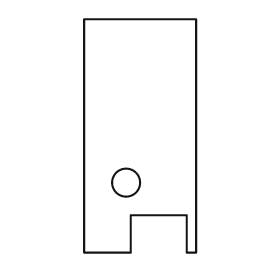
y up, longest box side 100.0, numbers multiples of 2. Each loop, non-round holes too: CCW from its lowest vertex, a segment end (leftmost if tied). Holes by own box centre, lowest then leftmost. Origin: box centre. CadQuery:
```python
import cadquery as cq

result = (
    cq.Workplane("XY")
    .moveTo(-24.0, -50.0)
    .lineTo(-4.0, -50.0)
    .lineTo(-4.0, -34.0)
    .lineTo(20.0, -34.0)
    .lineTo(20.0, -50.0)
    .lineTo(24.0, -50.0)
    .lineTo(24.0, 50.0)
    .lineTo(-24.0, 50.0)
    .close()
    .moveTo(-6.0, -20.0)
    .circle(6.0)
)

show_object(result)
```